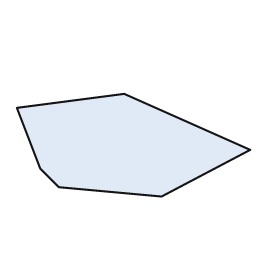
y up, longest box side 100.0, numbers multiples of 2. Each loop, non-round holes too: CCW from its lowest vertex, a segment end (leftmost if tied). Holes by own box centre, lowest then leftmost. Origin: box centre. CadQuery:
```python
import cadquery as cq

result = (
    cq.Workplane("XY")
    .moveTo(12.0, -22.0)
    .lineTo(50.0, -2.0)
    .lineTo(-4.0, 22.0)
    .lineTo(-50.0, 16.0)
    .lineTo(-40.0, -10.0)
    .lineTo(-32.0, -18.0)
    .close()
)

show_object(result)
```